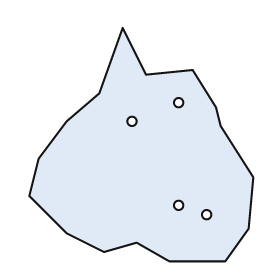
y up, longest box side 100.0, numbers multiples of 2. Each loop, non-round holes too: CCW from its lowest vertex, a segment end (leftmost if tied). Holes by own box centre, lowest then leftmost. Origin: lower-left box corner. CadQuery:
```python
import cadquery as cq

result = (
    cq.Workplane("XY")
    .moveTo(60.0, 0.0)
    .lineTo(84.0, 0.0)
    .lineTo(94.0, 14.0)
    .lineTo(96.0, 36.0)
    .lineTo(82.0, 58.0)
    .lineTo(80.0, 66.0)
    .lineTo(70.0, 82.0)
    .lineTo(50.0, 80.0)
    .lineTo(40.0, 100.0)
    .lineTo(30.0, 72.0)
    .lineTo(16.0, 60.0)
    .lineTo(4.0, 44.0)
    .lineTo(0.0, 28.0)
    .lineTo(16.0, 12.0)
    .lineTo(32.0, 4.0)
    .lineTo(46.0, 8.0)
    .close()
    .moveTo(76.0, 20.0)
    .circle(2.0)
    .moveTo(64.0, 24.0)
    .circle(2.0)
    .moveTo(44.0, 60.0)
    .circle(2.0)
    .moveTo(64.0, 68.0)
    .circle(2.0)
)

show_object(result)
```